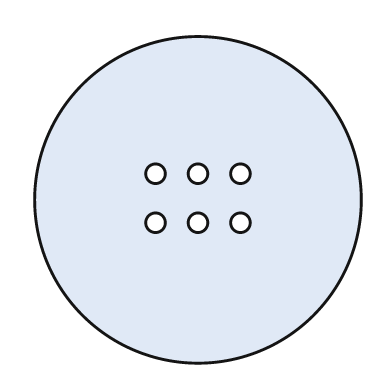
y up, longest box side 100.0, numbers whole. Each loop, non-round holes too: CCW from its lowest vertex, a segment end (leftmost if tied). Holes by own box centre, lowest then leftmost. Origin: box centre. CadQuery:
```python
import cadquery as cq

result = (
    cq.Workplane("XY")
    .moveTo(0.0, 0.0)
    .circle(50.0)
    .moveTo(-13.0, -7.0)
    .circle(3.0)
    .moveTo(0.0, -7.0)
    .circle(3.0)
    .moveTo(13.0, -7.0)
    .circle(3.0)
    .moveTo(-13.0, 8.0)
    .circle(3.0)
    .moveTo(0.0, 8.0)
    .circle(3.0)
    .moveTo(13.0, 8.0)
    .circle(3.0)
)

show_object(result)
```